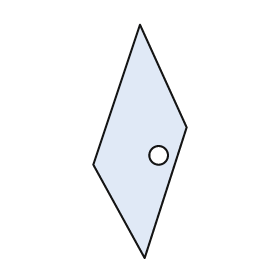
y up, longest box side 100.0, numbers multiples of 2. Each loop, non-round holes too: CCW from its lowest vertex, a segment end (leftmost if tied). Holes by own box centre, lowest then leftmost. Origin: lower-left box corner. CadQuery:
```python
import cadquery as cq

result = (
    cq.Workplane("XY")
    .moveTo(22.0, 0.0)
    .lineTo(40.0, 56.0)
    .lineTo(20.0, 100.0)
    .lineTo(0.0, 40.0)
    .close()
    .moveTo(28.0, 44.0)
    .circle(4.0)
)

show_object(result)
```